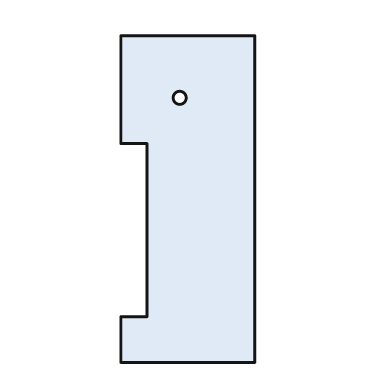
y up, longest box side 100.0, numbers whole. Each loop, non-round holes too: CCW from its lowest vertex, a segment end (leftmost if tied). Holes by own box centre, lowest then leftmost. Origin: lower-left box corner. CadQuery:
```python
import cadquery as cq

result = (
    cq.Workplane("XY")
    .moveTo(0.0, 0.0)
    .lineTo(41.0, 0.0)
    .lineTo(41.0, 100.0)
    .lineTo(0.0, 100.0)
    .lineTo(0.0, 67.0)
    .lineTo(8.0, 67.0)
    .lineTo(8.0, 14.0)
    .lineTo(0.0, 14.0)
    .close()
    .moveTo(18.0, 81.0)
    .circle(2.0)
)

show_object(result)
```